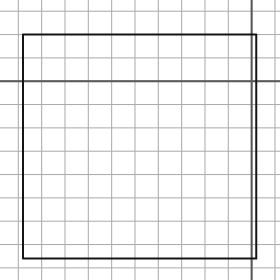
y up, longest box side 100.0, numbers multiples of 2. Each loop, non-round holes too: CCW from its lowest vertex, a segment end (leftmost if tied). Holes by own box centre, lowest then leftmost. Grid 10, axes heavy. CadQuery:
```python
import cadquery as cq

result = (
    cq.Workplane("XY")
    .moveTo(-98.0, -76.0)
    .lineTo(2.0, -76.0)
    .lineTo(2.0, 20.0)
    .lineTo(-98.0, 20.0)
    .close()
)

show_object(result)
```